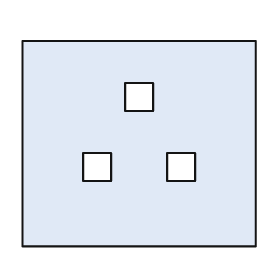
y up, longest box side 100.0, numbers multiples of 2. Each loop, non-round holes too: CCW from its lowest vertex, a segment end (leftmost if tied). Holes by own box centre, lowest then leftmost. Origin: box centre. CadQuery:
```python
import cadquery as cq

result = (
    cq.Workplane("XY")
    .moveTo(-50.0, -44.0)
    .lineTo(50.0, -44.0)
    .lineTo(50.0, 44.0)
    .lineTo(-50.0, 44.0)
    .close()
    .moveTo(-24.0, -16.0)
    .lineTo(-12.0, -16.0)
    .lineTo(-12.0, -4.0)
    .lineTo(-24.0, -4.0)
    .close()
    .moveTo(12.0, -16.0)
    .lineTo(24.0, -16.0)
    .lineTo(24.0, -4.0)
    .lineTo(12.0, -4.0)
    .close()
    .moveTo(-6.0, 14.0)
    .lineTo(6.0, 14.0)
    .lineTo(6.0, 26.0)
    .lineTo(-6.0, 26.0)
    .close()
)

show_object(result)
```